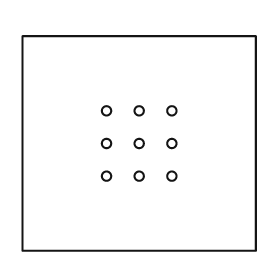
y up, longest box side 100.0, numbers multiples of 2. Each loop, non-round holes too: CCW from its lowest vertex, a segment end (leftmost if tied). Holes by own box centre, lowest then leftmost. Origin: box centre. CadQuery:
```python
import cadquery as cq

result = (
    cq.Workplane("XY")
    .moveTo(-50.0, -46.0)
    .lineTo(50.0, -46.0)
    .lineTo(50.0, 46.0)
    .lineTo(-50.0, 46.0)
    .close()
    .moveTo(-14.0, -14.0)
    .circle(2.0)
    .moveTo(0.0, -14.0)
    .circle(2.0)
    .moveTo(14.0, -14.0)
    .circle(2.0)
    .moveTo(-14.0, 0.0)
    .circle(2.0)
    .moveTo(0.0, 0.0)
    .circle(2.0)
    .moveTo(14.0, 0.0)
    .circle(2.0)
    .moveTo(-14.0, 14.0)
    .circle(2.0)
    .moveTo(0.0, 14.0)
    .circle(2.0)
    .moveTo(14.0, 14.0)
    .circle(2.0)
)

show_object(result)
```